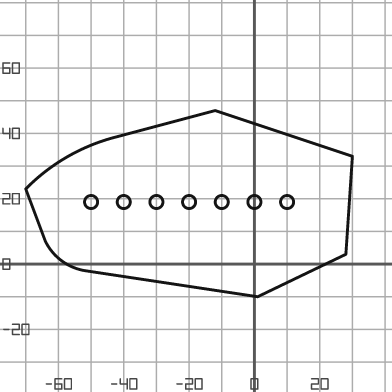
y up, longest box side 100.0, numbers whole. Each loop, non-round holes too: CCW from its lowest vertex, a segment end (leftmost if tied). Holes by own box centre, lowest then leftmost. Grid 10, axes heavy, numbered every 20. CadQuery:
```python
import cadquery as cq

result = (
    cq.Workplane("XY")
    .moveTo(1.0, -10.0)
    .lineTo(28.0, 3.0)
    .lineTo(30.0, 33.0)
    .lineTo(-12.0, 47.0)
    .lineTo(-42.0, 39.0)
    .threePointArc((-57.0, 33.0), (-70.0, 23.0))
    .lineTo(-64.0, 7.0)
    .threePointArc((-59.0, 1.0), (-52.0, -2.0))
    .close()
    .moveTo(-50.0, 19.0)
    .circle(2.0)
    .moveTo(-40.0, 19.0)
    .circle(2.0)
    .moveTo(-30.0, 19.0)
    .circle(2.0)
    .moveTo(-20.0, 19.0)
    .circle(2.0)
    .moveTo(-10.0, 19.0)
    .circle(2.0)
    .moveTo(0.0, 19.0)
    .circle(2.0)
    .moveTo(10.0, 19.0)
    .circle(2.0)
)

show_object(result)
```